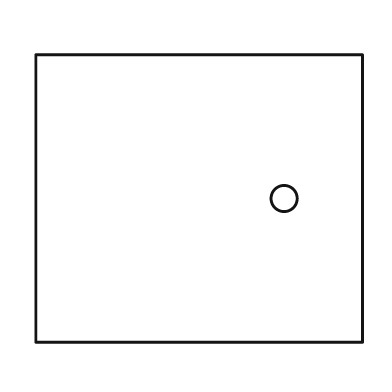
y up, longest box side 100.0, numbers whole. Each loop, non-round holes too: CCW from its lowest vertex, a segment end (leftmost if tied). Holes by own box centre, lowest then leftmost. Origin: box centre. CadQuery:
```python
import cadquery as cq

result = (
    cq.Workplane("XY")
    .moveTo(-50.0, -44.0)
    .lineTo(50.0, -44.0)
    .lineTo(50.0, 44.0)
    .lineTo(-50.0, 44.0)
    .close()
    .moveTo(26.0, 0.0)
    .circle(4.0)
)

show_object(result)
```